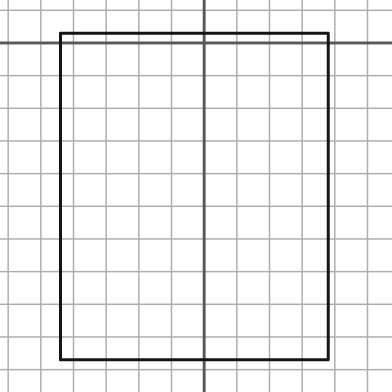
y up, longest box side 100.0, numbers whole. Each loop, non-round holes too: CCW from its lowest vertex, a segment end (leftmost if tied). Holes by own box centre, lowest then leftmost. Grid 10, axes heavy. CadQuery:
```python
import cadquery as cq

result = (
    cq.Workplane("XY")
    .moveTo(-44.0, -97.0)
    .lineTo(38.0, -97.0)
    .lineTo(38.0, 3.0)
    .lineTo(-44.0, 3.0)
    .close()
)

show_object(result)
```